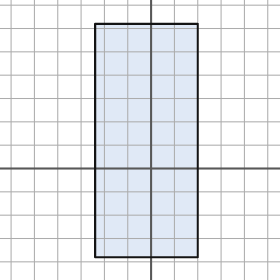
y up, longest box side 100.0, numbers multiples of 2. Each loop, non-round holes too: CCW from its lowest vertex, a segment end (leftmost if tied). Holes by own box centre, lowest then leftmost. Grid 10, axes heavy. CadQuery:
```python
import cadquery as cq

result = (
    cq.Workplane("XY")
    .moveTo(-24.0, -38.0)
    .lineTo(20.0, -38.0)
    .lineTo(20.0, 62.0)
    .lineTo(-24.0, 62.0)
    .close()
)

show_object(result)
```